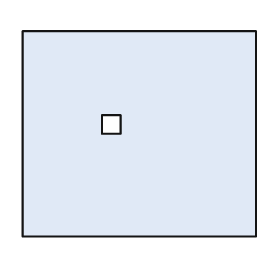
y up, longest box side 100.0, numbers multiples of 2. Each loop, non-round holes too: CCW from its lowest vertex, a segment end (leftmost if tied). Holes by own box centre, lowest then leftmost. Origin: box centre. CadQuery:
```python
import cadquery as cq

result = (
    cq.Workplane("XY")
    .moveTo(-50.0, -44.0)
    .lineTo(50.0, -44.0)
    .lineTo(50.0, 44.0)
    .lineTo(-50.0, 44.0)
    .close()
    .moveTo(-16.0, 0.0)
    .lineTo(-8.0, 0.0)
    .lineTo(-8.0, 8.0)
    .lineTo(-16.0, 8.0)
    .close()
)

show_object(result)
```